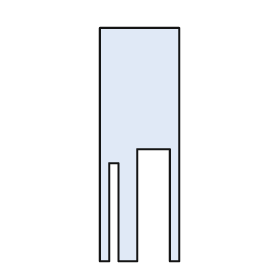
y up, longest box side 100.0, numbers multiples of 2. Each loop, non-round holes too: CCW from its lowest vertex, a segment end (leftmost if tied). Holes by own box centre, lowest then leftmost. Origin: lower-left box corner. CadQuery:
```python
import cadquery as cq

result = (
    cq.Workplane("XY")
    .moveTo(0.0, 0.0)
    .lineTo(4.0, 0.0)
    .lineTo(4.0, 42.0)
    .lineTo(8.0, 42.0)
    .lineTo(8.0, 0.0)
    .lineTo(16.0, 0.0)
    .lineTo(16.0, 48.0)
    .lineTo(30.0, 48.0)
    .lineTo(30.0, 0.0)
    .lineTo(34.0, 0.0)
    .lineTo(34.0, 100.0)
    .lineTo(0.0, 100.0)
    .close()
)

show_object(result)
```